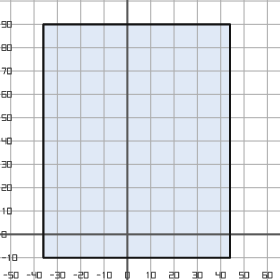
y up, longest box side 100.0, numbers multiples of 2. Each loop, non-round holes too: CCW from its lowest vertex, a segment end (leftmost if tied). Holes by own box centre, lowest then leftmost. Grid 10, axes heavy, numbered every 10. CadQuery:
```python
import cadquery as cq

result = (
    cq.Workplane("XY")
    .moveTo(-36.0, -10.0)
    .lineTo(44.0, -10.0)
    .lineTo(44.0, 90.0)
    .lineTo(-36.0, 90.0)
    .close()
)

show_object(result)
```